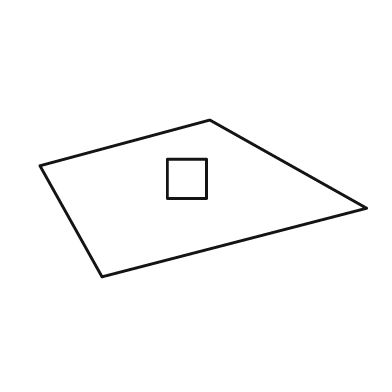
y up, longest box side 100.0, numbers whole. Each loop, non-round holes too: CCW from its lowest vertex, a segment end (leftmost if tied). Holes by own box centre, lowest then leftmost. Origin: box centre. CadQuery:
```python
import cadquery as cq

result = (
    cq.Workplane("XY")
    .moveTo(-31.0, -24.0)
    .lineTo(50.0, -3.0)
    .lineTo(2.0, 24.0)
    .lineTo(-50.0, 10.0)
    .close()
    .moveTo(-11.0, 0.0)
    .lineTo(1.0, 0.0)
    .lineTo(1.0, 12.0)
    .lineTo(-11.0, 12.0)
    .close()
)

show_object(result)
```